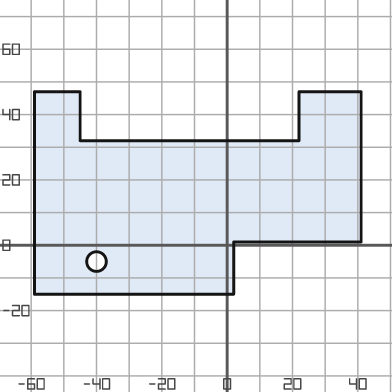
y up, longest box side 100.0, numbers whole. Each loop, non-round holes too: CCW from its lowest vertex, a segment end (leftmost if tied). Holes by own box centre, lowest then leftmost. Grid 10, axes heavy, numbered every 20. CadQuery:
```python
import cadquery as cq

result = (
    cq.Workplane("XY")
    .moveTo(-59.0, -15.0)
    .lineTo(2.0, -15.0)
    .lineTo(2.0, 1.0)
    .lineTo(41.0, 1.0)
    .lineTo(41.0, 47.0)
    .lineTo(22.0, 47.0)
    .lineTo(22.0, 32.0)
    .lineTo(-45.0, 32.0)
    .lineTo(-45.0, 47.0)
    .lineTo(-59.0, 47.0)
    .close()
    .moveTo(-40.0, -5.0)
    .circle(3.0)
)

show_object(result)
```